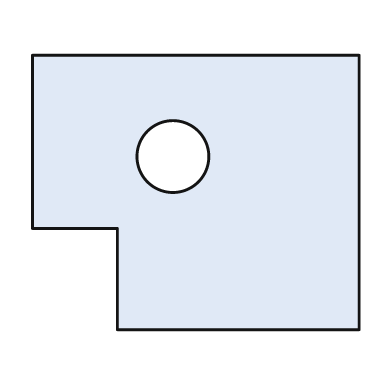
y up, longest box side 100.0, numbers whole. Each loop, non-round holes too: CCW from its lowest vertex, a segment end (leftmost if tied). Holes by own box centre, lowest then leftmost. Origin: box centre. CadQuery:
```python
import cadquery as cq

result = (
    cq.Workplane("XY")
    .moveTo(-24.0, -42.0)
    .lineTo(50.0, -42.0)
    .lineTo(50.0, 42.0)
    .lineTo(-50.0, 42.0)
    .lineTo(-50.0, -11.0)
    .lineTo(-24.0, -11.0)
    .close()
    .moveTo(-7.0, 11.0)
    .circle(11.0)
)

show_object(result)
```